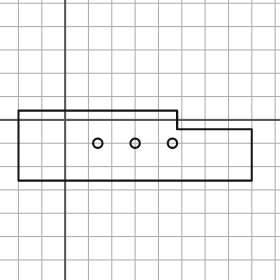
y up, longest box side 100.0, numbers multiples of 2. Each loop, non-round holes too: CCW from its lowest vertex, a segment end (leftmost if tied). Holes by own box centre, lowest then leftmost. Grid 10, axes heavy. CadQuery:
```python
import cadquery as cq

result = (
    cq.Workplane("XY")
    .moveTo(-20.0, -26.0)
    .lineTo(80.0, -26.0)
    .lineTo(80.0, -4.0)
    .lineTo(48.0, -4.0)
    .lineTo(48.0, 4.0)
    .lineTo(-20.0, 4.0)
    .close()
    .moveTo(14.0, -10.0)
    .circle(2.0)
    .moveTo(30.0, -10.0)
    .circle(2.0)
    .moveTo(46.0, -10.0)
    .circle(2.0)
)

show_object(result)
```